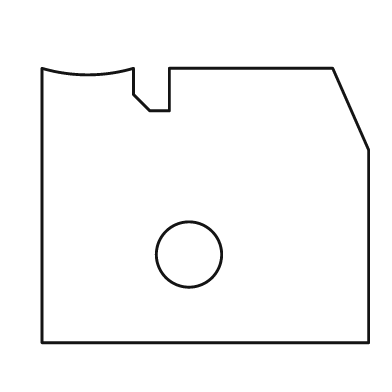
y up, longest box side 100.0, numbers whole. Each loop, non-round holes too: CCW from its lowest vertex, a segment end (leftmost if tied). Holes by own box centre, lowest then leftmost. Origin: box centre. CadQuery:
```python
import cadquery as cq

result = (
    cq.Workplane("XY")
    .moveTo(-50.0, -42.0)
    .lineTo(50.0, -42.0)
    .lineTo(50.0, 17.0)
    .lineTo(39.0, 42.0)
    .lineTo(-11.0, 42.0)
    .lineTo(-11.0, 29.0)
    .lineTo(-17.0, 29.0)
    .lineTo(-22.0, 34.0)
    .lineTo(-22.0, 42.0)
    .threePointArc((-36.0, 40.0), (-50.0, 42.0))
    .close()
    .moveTo(-5.0, -15.0)
    .circle(10.0)
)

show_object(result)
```